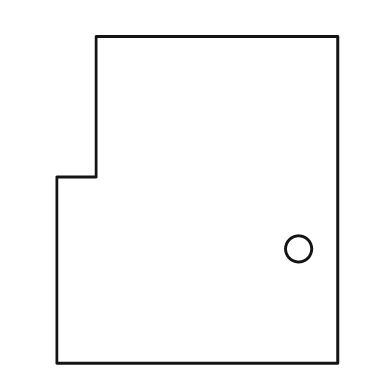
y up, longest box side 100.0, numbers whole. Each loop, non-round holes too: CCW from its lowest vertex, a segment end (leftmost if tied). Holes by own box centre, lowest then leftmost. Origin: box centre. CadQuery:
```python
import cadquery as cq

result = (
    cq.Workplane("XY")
    .moveTo(-43.0, -50.0)
    .lineTo(43.0, -50.0)
    .lineTo(43.0, 50.0)
    .lineTo(-31.0, 50.0)
    .lineTo(-31.0, 7.0)
    .lineTo(-43.0, 7.0)
    .close()
    .moveTo(31.0, -15.0)
    .circle(4.0)
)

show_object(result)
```